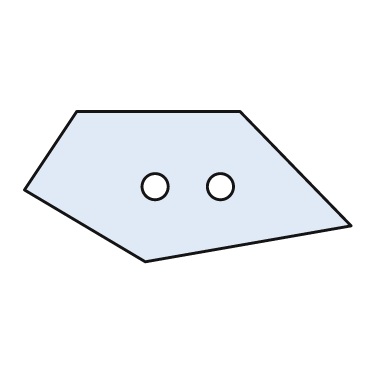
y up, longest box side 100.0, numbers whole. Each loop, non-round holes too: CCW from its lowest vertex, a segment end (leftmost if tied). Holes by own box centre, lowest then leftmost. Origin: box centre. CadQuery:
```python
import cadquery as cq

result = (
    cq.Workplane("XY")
    .moveTo(-13.0, -23.0)
    .lineTo(50.0, -12.0)
    .lineTo(16.0, 23.0)
    .lineTo(-34.0, 23.0)
    .lineTo(-50.0, -1.0)
    .close()
    .moveTo(-10.0, 0.0)
    .circle(4.0)
    .moveTo(10.0, 0.0)
    .circle(4.0)
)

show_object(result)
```